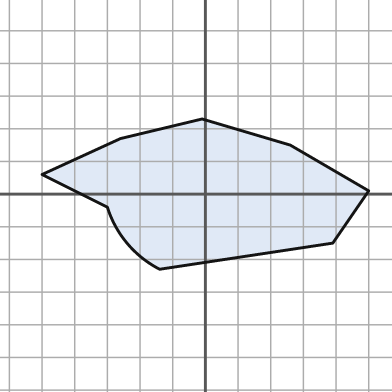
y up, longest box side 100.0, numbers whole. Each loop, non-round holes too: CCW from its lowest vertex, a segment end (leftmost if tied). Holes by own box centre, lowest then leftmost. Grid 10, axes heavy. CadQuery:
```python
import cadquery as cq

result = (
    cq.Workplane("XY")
    .moveTo(-14.0, -23.0)
    .lineTo(39.0, -15.0)
    .lineTo(50.0, 1.0)
    .lineTo(26.0, 15.0)
    .lineTo(-1.0, 23.0)
    .lineTo(-26.0, 17.0)
    .lineTo(-50.0, 6.0)
    .lineTo(-30.0, -4.0)
    .threePointArc((-24.0, -15.0), (-14.0, -23.0))
    .close()
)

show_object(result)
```